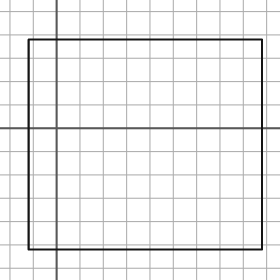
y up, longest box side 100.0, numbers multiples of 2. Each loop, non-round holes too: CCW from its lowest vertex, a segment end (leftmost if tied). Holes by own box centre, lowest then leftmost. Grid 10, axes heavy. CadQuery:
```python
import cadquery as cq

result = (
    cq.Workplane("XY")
    .moveTo(-12.0, -52.0)
    .lineTo(88.0, -52.0)
    .lineTo(88.0, 38.0)
    .lineTo(-12.0, 38.0)
    .close()
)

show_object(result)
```